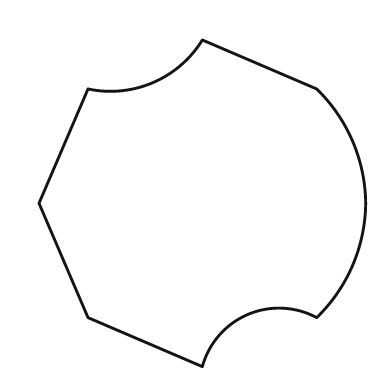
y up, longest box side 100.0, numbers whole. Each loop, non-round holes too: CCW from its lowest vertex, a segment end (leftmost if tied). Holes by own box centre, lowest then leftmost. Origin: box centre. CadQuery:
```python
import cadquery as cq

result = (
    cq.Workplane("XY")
    .moveTo(0.0, -50.0)
    .threePointArc((14.0, -34.0), (35.0, -35.0))
    .threePointArc((46.0, -19.0), (50.0, 0.0))
    .threePointArc((46.0, 19.0), (35.0, 35.0))
    .lineTo(0.0, 50.0)
    .threePointArc((-15.0, 37.0), (-35.0, 35.0))
    .lineTo(-50.0, 0.0)
    .lineTo(-35.0, -35.0)
    .close()
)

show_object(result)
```